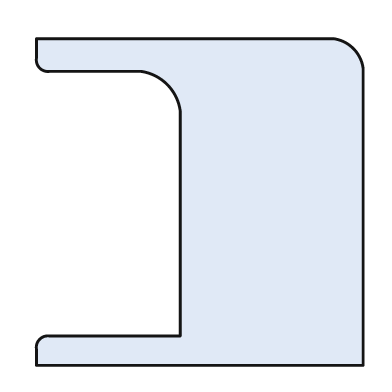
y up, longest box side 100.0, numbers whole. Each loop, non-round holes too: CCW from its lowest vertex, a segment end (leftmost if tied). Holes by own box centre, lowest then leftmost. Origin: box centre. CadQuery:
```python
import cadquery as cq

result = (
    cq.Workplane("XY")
    .moveTo(-50.0, -50.0)
    .lineTo(50.0, -50.0)
    .lineTo(50.0, 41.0)
    .threePointArc((47.0, 47.0), (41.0, 50.0))
    .lineTo(-50.0, 50.0)
    .lineTo(-50.0, 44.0)
    .threePointArc((-49.0, 41.0), (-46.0, 40.0))
    .lineTo(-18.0, 40.0)
    .threePointArc((-10.0, 36.0), (-6.0, 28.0))
    .lineTo(-6.0, -41.0)
    .lineTo(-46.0, -41.0)
    .threePointArc((-49.0, -42.0), (-50.0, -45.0))
    .close()
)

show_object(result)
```